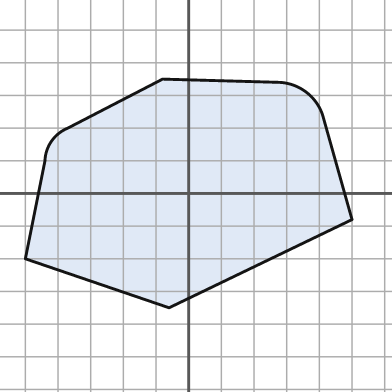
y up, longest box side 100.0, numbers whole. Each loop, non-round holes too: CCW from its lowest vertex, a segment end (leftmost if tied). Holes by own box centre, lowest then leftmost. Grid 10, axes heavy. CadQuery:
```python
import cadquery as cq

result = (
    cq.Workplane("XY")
    .moveTo(-6.0, -35.0)
    .lineTo(50.0, -8.0)
    .lineTo(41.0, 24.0)
    .threePointArc((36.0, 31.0), (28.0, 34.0))
    .lineTo(-8.0, 35.0)
    .lineTo(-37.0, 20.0)
    .threePointArc((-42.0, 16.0), (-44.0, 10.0))
    .lineTo(-50.0, -20.0)
    .close()
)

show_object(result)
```